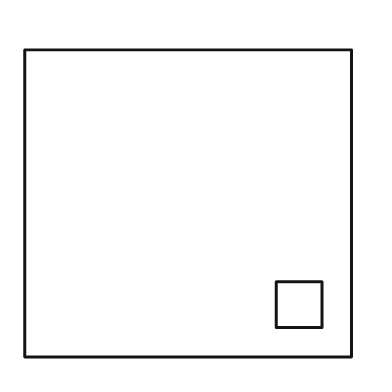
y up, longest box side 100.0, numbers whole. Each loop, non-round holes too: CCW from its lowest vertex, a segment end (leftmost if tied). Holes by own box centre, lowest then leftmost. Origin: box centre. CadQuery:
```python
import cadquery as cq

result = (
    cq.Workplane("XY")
    .moveTo(-50.0, -47.0)
    .lineTo(50.0, -47.0)
    .lineTo(50.0, 47.0)
    .lineTo(-50.0, 47.0)
    .close()
    .moveTo(27.0, -38.0)
    .lineTo(41.0, -38.0)
    .lineTo(41.0, -24.0)
    .lineTo(27.0, -24.0)
    .close()
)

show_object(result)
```